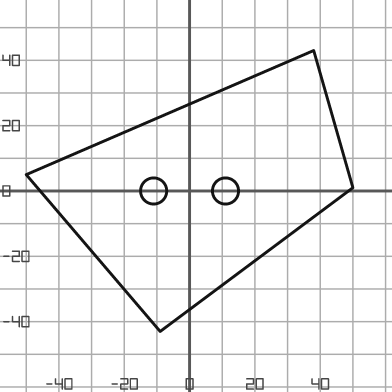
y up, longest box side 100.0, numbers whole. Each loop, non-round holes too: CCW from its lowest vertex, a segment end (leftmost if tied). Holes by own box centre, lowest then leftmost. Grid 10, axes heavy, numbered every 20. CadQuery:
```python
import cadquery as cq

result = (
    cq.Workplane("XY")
    .moveTo(-9.0, -43.0)
    .lineTo(50.0, 1.0)
    .lineTo(38.0, 43.0)
    .lineTo(-50.0, 5.0)
    .close()
    .moveTo(-11.0, 0.0)
    .circle(4.0)
    .moveTo(11.0, 0.0)
    .circle(4.0)
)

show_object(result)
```